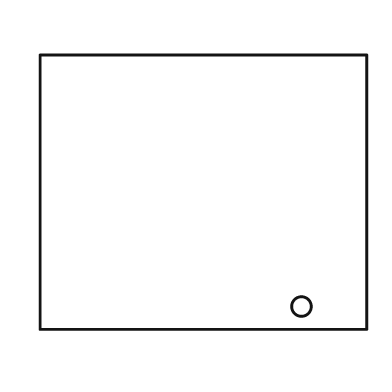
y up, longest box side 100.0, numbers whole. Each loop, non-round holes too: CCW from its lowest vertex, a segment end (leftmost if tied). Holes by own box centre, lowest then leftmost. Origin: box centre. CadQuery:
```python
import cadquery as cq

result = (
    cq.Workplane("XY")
    .moveTo(-50.0, -42.0)
    .lineTo(50.0, -42.0)
    .lineTo(50.0, 42.0)
    .lineTo(-50.0, 42.0)
    .close()
    .moveTo(30.0, -35.0)
    .circle(3.0)
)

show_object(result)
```